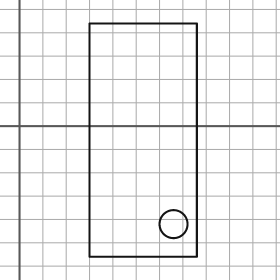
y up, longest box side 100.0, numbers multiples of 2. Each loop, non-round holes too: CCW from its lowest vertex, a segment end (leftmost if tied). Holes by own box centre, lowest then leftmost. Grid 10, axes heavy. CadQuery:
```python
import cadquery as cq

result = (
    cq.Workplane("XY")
    .moveTo(30.0, -56.0)
    .lineTo(76.0, -56.0)
    .lineTo(76.0, 44.0)
    .lineTo(30.0, 44.0)
    .close()
    .moveTo(66.0, -42.0)
    .circle(6.0)
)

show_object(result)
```